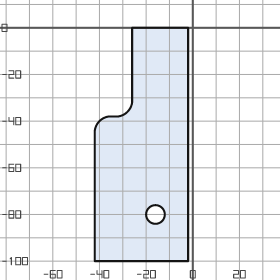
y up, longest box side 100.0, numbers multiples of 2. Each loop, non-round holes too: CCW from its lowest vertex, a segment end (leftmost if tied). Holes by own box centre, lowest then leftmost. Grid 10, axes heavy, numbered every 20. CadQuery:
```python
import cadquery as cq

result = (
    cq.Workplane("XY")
    .moveTo(-42.0, -100.0)
    .lineTo(-2.0, -100.0)
    .lineTo(-2.0, 0.0)
    .lineTo(-26.0, 0.0)
    .lineTo(-26.0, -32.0)
    .threePointArc((-28.0, -36.0), (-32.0, -38.0))
    .lineTo(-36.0, -38.0)
    .threePointArc((-40.0, -40.0), (-42.0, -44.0))
    .close()
    .moveTo(-16.0, -80.0)
    .circle(4.0)
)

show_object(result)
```